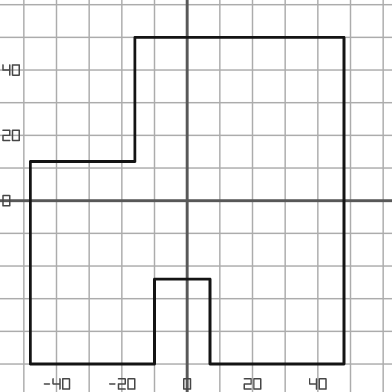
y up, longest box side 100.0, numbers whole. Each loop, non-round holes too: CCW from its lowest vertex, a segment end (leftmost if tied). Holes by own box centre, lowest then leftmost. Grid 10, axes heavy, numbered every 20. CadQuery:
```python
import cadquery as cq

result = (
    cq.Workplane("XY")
    .moveTo(-48.0, -50.0)
    .lineTo(-10.0, -50.0)
    .lineTo(-10.0, -24.0)
    .lineTo(7.0, -24.0)
    .lineTo(7.0, -50.0)
    .lineTo(48.0, -50.0)
    .lineTo(48.0, 50.0)
    .lineTo(-16.0, 50.0)
    .lineTo(-16.0, 12.0)
    .lineTo(-48.0, 12.0)
    .close()
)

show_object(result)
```